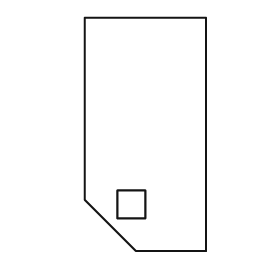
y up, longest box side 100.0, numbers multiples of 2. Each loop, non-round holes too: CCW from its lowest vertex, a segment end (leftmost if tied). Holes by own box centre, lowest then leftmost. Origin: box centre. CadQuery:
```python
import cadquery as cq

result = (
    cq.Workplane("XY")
    .moveTo(-4.0, -50.0)
    .lineTo(26.0, -50.0)
    .lineTo(26.0, 50.0)
    .lineTo(-26.0, 50.0)
    .lineTo(-26.0, -28.0)
    .close()
    .moveTo(-12.0, -36.0)
    .lineTo(0.0, -36.0)
    .lineTo(0.0, -24.0)
    .lineTo(-12.0, -24.0)
    .close()
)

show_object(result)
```